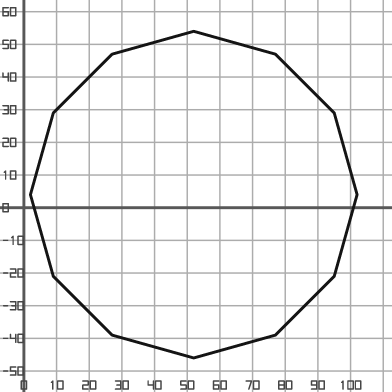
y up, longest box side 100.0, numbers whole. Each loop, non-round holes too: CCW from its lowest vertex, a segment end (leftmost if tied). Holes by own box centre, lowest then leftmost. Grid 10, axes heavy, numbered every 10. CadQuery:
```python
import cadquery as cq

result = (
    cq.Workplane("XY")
    .moveTo(52.0, -46.0)
    .lineTo(77.0, -39.0)
    .lineTo(95.0, -21.0)
    .lineTo(102.0, 4.0)
    .lineTo(95.0, 29.0)
    .lineTo(77.0, 47.0)
    .lineTo(52.0, 54.0)
    .lineTo(27.0, 47.0)
    .lineTo(9.0, 29.0)
    .lineTo(2.0, 4.0)
    .lineTo(9.0, -21.0)
    .lineTo(27.0, -39.0)
    .close()
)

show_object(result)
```